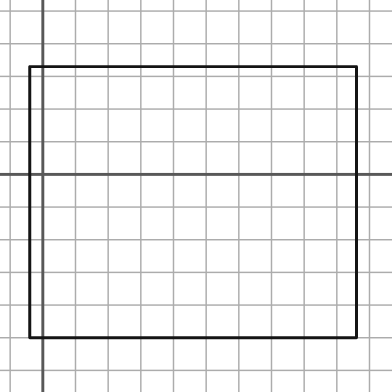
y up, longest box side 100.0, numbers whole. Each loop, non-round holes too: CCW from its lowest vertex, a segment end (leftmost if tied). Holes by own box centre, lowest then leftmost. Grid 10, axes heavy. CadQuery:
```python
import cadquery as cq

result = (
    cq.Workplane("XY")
    .moveTo(-4.0, -50.0)
    .lineTo(96.0, -50.0)
    .lineTo(96.0, 33.0)
    .lineTo(-4.0, 33.0)
    .close()
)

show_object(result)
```